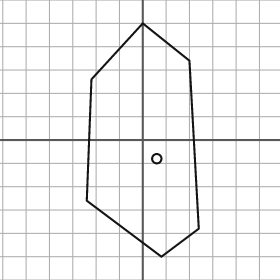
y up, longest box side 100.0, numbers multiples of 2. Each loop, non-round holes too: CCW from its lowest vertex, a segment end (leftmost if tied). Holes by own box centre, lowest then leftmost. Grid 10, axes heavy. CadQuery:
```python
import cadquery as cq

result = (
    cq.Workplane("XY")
    .moveTo(8.0, -50.0)
    .lineTo(24.0, -38.0)
    .lineTo(20.0, 34.0)
    .lineTo(0.0, 50.0)
    .lineTo(-22.0, 26.0)
    .lineTo(-24.0, -26.0)
    .close()
    .moveTo(6.0, -8.0)
    .circle(2.0)
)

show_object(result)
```